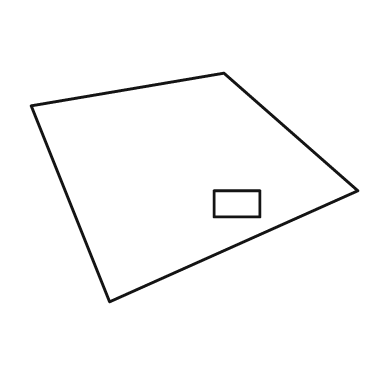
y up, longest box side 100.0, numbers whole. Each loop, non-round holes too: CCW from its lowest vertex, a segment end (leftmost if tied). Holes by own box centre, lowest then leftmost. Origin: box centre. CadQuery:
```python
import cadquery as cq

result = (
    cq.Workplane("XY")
    .moveTo(-26.0, -35.0)
    .lineTo(50.0, -1.0)
    .lineTo(9.0, 35.0)
    .lineTo(-50.0, 25.0)
    .close()
    .moveTo(6.0, -9.0)
    .lineTo(20.0, -9.0)
    .lineTo(20.0, -1.0)
    .lineTo(6.0, -1.0)
    .close()
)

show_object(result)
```